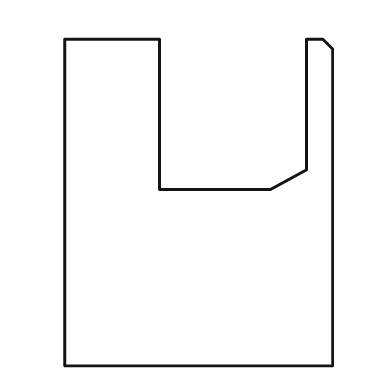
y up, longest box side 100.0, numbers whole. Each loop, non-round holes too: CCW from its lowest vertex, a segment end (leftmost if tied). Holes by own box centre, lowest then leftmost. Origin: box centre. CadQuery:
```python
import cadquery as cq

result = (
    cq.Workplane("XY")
    .moveTo(-41.0, -50.0)
    .lineTo(41.0, -50.0)
    .lineTo(41.0, 47.0)
    .lineTo(38.0, 50.0)
    .lineTo(33.0, 50.0)
    .lineTo(33.0, 10.0)
    .lineTo(22.0, 4.0)
    .lineTo(-12.0, 4.0)
    .lineTo(-12.0, 50.0)
    .lineTo(-41.0, 50.0)
    .close()
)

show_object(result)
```